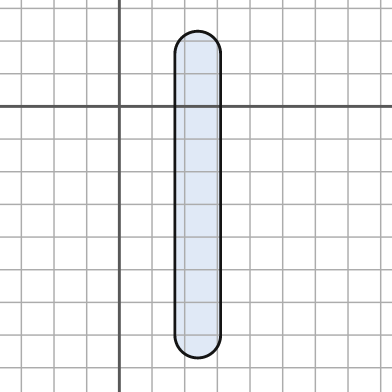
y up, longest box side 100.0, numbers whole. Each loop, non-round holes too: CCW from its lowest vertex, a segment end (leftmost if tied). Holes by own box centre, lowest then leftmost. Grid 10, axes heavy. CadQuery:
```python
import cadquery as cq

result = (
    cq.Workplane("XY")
    .moveTo(17.0, -70.0)
    .threePointArc((24.0, -77.0), (31.0, -70.0))
    .lineTo(31.0, 16.0)
    .threePointArc((24.0, 23.0), (17.0, 16.0))
    .close()
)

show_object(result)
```